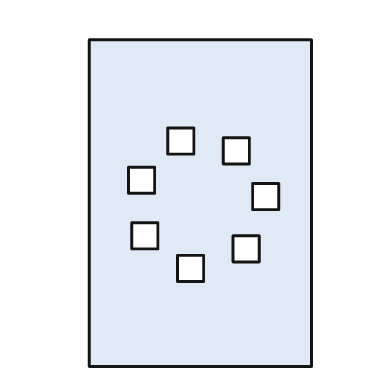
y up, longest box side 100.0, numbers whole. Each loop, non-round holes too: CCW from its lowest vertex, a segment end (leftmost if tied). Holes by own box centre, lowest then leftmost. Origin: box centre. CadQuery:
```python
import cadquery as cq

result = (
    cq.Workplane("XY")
    .moveTo(-34.0, -50.0)
    .lineTo(34.0, -50.0)
    .lineTo(34.0, 50.0)
    .lineTo(-34.0, 50.0)
    .close()
    .moveTo(-7.0, -24.0)
    .lineTo(1.0, -24.0)
    .lineTo(1.0, -16.0)
    .lineTo(-7.0, -16.0)
    .close()
    .moveTo(10.0, -18.0)
    .lineTo(18.0, -18.0)
    .lineTo(18.0, -10.0)
    .lineTo(10.0, -10.0)
    .close()
    .moveTo(-21.0, -14.0)
    .lineTo(-13.0, -14.0)
    .lineTo(-13.0, -6.0)
    .lineTo(-21.0, -6.0)
    .close()
    .moveTo(16.0, -2.0)
    .lineTo(24.0, -2.0)
    .lineTo(24.0, 6.0)
    .lineTo(16.0, 6.0)
    .close()
    .moveTo(-22.0, 3.0)
    .lineTo(-14.0, 3.0)
    .lineTo(-14.0, 11.0)
    .lineTo(-22.0, 11.0)
    .close()
    .moveTo(7.0, 12.0)
    .lineTo(15.0, 12.0)
    .lineTo(15.0, 20.0)
    .lineTo(7.0, 20.0)
    .close()
    .moveTo(-10.0, 15.0)
    .lineTo(-2.0, 15.0)
    .lineTo(-2.0, 23.0)
    .lineTo(-10.0, 23.0)
    .close()
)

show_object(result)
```